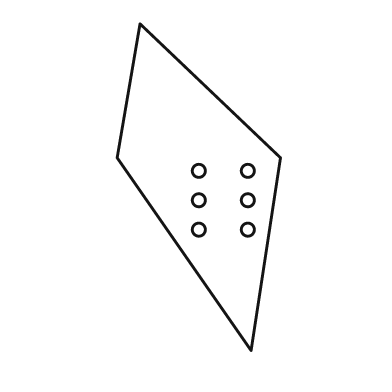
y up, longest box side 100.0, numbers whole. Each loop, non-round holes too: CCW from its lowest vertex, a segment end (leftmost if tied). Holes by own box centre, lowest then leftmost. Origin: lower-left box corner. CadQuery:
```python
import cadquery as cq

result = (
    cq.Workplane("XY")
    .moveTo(41.0, 0.0)
    .lineTo(50.0, 59.0)
    .lineTo(7.0, 100.0)
    .lineTo(0.0, 59.0)
    .close()
    .moveTo(25.0, 37.0)
    .circle(2.0)
    .moveTo(40.0, 37.0)
    .circle(2.0)
    .moveTo(25.0, 46.0)
    .circle(2.0)
    .moveTo(40.0, 46.0)
    .circle(2.0)
    .moveTo(25.0, 55.0)
    .circle(2.0)
    .moveTo(40.0, 55.0)
    .circle(2.0)
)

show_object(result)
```